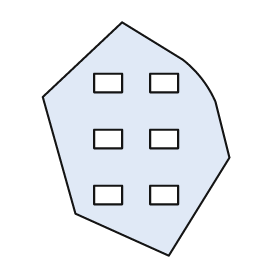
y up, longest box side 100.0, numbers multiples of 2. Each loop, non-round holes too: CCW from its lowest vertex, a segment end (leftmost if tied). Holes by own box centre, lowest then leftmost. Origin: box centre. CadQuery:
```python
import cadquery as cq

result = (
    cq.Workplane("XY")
    .moveTo(14.0, -50.0)
    .lineTo(40.0, -8.0)
    .lineTo(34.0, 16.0)
    .threePointArc((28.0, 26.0), (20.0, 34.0))
    .lineTo(-6.0, 50.0)
    .lineTo(-40.0, 18.0)
    .lineTo(-26.0, -32.0)
    .close()
    .moveTo(-18.0, -28.0)
    .lineTo(-6.0, -28.0)
    .lineTo(-6.0, -20.0)
    .lineTo(-18.0, -20.0)
    .close()
    .moveTo(6.0, -28.0)
    .lineTo(18.0, -28.0)
    .lineTo(18.0, -20.0)
    .lineTo(6.0, -20.0)
    .close()
    .moveTo(-18.0, -4.0)
    .lineTo(-6.0, -4.0)
    .lineTo(-6.0, 4.0)
    .lineTo(-18.0, 4.0)
    .close()
    .moveTo(6.0, -4.0)
    .lineTo(18.0, -4.0)
    .lineTo(18.0, 4.0)
    .lineTo(6.0, 4.0)
    .close()
    .moveTo(-18.0, 20.0)
    .lineTo(-6.0, 20.0)
    .lineTo(-6.0, 28.0)
    .lineTo(-18.0, 28.0)
    .close()
    .moveTo(6.0, 20.0)
    .lineTo(18.0, 20.0)
    .lineTo(18.0, 28.0)
    .lineTo(6.0, 28.0)
    .close()
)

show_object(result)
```